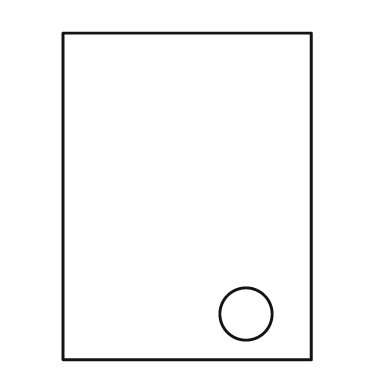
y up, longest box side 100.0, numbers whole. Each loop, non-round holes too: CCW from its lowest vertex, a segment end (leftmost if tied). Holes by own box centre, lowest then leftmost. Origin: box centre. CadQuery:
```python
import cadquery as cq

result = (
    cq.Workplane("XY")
    .moveTo(-38.0, -50.0)
    .lineTo(38.0, -50.0)
    .lineTo(38.0, 50.0)
    .lineTo(-38.0, 50.0)
    .close()
    .moveTo(18.0, -36.0)
    .circle(8.0)
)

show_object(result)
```